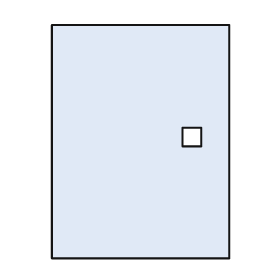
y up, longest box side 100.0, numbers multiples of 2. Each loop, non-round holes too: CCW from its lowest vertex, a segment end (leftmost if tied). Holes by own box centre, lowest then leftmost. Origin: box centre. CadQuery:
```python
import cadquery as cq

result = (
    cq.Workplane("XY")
    .moveTo(-38.0, -50.0)
    .lineTo(38.0, -50.0)
    .lineTo(38.0, 50.0)
    .lineTo(-38.0, 50.0)
    .close()
    .moveTo(18.0, -2.0)
    .lineTo(26.0, -2.0)
    .lineTo(26.0, 6.0)
    .lineTo(18.0, 6.0)
    .close()
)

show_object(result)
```